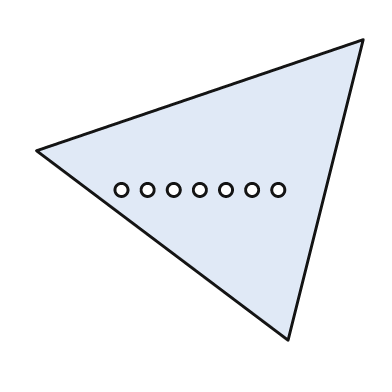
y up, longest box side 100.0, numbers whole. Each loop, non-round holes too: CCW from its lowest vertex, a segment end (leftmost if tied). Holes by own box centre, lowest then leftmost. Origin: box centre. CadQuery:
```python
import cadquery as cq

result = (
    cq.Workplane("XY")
    .moveTo(27.0, -46.0)
    .lineTo(50.0, 46.0)
    .lineTo(-50.0, 12.0)
    .close()
    .moveTo(-24.0, 0.0)
    .circle(2.0)
    .moveTo(-16.0, 0.0)
    .circle(2.0)
    .moveTo(-8.0, 0.0)
    .circle(2.0)
    .moveTo(0.0, 0.0)
    .circle(2.0)
    .moveTo(8.0, 0.0)
    .circle(2.0)
    .moveTo(16.0, 0.0)
    .circle(2.0)
    .moveTo(24.0, 0.0)
    .circle(2.0)
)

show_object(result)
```